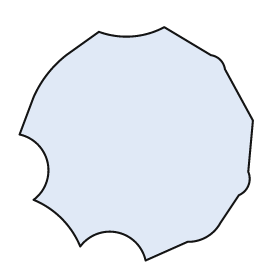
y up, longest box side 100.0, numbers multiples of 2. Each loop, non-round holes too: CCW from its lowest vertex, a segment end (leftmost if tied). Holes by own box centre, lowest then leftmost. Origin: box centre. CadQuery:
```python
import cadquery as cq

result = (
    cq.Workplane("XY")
    .moveTo(4.0, -50.0)
    .lineTo(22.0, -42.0)
    .threePointArc((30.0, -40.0), (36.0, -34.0))
    .lineTo(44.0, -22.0)
    .threePointArc((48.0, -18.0), (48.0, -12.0))
    .lineTo(50.0, 10.0)
    .lineTo(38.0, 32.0)
    .threePointArc((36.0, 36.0), (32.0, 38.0))
    .lineTo(12.0, 50.0)
    .threePointArc((-2.0, 46.0), (-16.0, 48.0))
    .lineTo(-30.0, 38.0)
    .threePointArc((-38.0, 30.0), (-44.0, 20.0))
    .lineTo(-50.0, 4.0)
    .threePointArc((-38.0, -8.0), (-44.0, -24.0))
    .threePointArc((-32.0, -32.0), (-24.0, -44.0))
    .threePointArc((-8.0, -38.0), (4.0, -50.0))
    .close()
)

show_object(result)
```